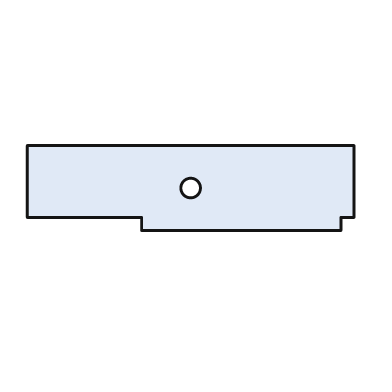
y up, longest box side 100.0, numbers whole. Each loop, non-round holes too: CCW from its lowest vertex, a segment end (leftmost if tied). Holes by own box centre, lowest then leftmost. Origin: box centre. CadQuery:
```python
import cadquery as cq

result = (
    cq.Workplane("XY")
    .moveTo(-15.0, -13.0)
    .lineTo(46.0, -13.0)
    .lineTo(46.0, -9.0)
    .lineTo(50.0, -9.0)
    .lineTo(50.0, 13.0)
    .lineTo(-50.0, 13.0)
    .lineTo(-50.0, -9.0)
    .lineTo(-15.0, -9.0)
    .close()
    .moveTo(0.0, 0.0)
    .circle(3.0)
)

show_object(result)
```